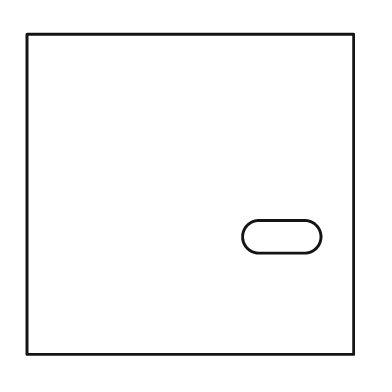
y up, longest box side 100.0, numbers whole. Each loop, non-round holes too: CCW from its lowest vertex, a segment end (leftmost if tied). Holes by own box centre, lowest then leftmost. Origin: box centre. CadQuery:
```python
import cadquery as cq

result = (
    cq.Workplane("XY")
    .moveTo(-50.0, -49.0)
    .lineTo(50.0, -49.0)
    .lineTo(50.0, 49.0)
    .lineTo(-50.0, 49.0)
    .close()
    .moveTo(21.0, -18.0)
    .lineTo(35.0, -18.0)
    .threePointArc((40.0, -13.0), (35.0, -8.0))
    .lineTo(21.0, -8.0)
    .threePointArc((16.0, -13.0), (21.0, -18.0))
    .close()
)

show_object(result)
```